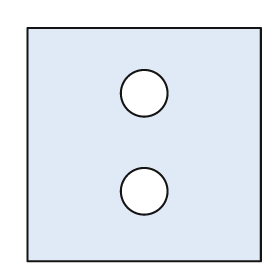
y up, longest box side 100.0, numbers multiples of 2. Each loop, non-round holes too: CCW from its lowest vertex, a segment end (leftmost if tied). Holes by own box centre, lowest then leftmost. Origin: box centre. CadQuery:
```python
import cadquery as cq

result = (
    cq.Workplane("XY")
    .moveTo(-50.0, -50.0)
    .lineTo(50.0, -50.0)
    .lineTo(50.0, 50.0)
    .lineTo(-50.0, 50.0)
    .close()
    .moveTo(0.0, -20.0)
    .circle(10.0)
    .moveTo(0.0, 22.0)
    .circle(10.0)
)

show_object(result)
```